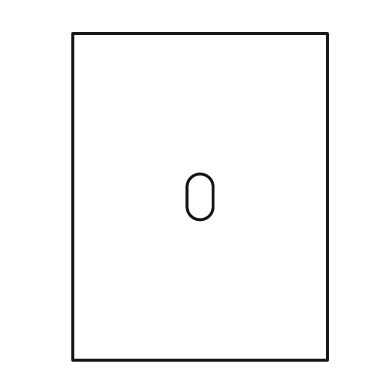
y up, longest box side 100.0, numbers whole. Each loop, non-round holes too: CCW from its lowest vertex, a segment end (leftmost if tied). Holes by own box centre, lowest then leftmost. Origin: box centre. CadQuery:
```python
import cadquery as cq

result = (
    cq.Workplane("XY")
    .moveTo(-39.0, -50.0)
    .lineTo(39.0, -50.0)
    .lineTo(39.0, 50.0)
    .lineTo(-39.0, 50.0)
    .close()
    .moveTo(-4.0, -3.0)
    .threePointArc((0.0, -7.0), (4.0, -3.0))
    .lineTo(4.0, 3.0)
    .threePointArc((0.0, 7.0), (-4.0, 3.0))
    .close()
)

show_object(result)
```